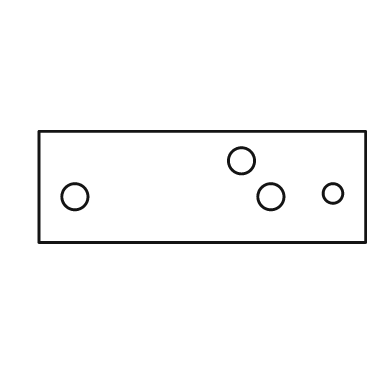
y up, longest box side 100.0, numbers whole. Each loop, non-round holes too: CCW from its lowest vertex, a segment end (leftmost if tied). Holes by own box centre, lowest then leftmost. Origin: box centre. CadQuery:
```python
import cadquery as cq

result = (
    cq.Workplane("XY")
    .moveTo(-50.0, -17.0)
    .lineTo(50.0, -17.0)
    .lineTo(50.0, 17.0)
    .lineTo(-50.0, 17.0)
    .close()
    .moveTo(-39.0, -3.0)
    .circle(4.0)
    .moveTo(21.0, -3.0)
    .circle(4.0)
    .moveTo(40.0, -2.0)
    .circle(3.0)
    .moveTo(12.0, 8.0)
    .circle(4.0)
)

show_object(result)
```